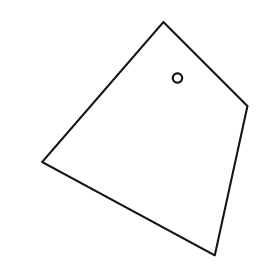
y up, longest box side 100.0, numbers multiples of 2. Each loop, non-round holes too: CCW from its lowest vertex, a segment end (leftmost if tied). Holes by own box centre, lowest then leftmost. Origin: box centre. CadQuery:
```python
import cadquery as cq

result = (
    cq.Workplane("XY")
    .moveTo(30.0, -50.0)
    .lineTo(44.0, 14.0)
    .lineTo(8.0, 50.0)
    .lineTo(-44.0, -10.0)
    .close()
    .moveTo(14.0, 26.0)
    .circle(2.0)
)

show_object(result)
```